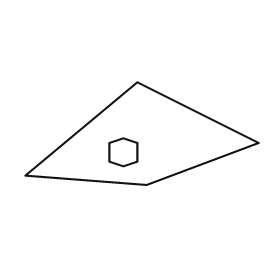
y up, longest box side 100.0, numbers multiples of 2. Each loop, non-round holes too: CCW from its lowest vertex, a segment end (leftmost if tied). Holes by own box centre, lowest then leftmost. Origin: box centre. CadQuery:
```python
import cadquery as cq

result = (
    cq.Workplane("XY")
    .moveTo(2.0, -22.0)
    .lineTo(50.0, -4.0)
    .lineTo(-2.0, 22.0)
    .lineTo(-50.0, -18.0)
    .close()
    .moveTo(-8.0, -14.0)
    .lineTo(-2.0, -12.0)
    .lineTo(-2.0, -4.0)
    .lineTo(-8.0, -2.0)
    .lineTo(-14.0, -4.0)
    .lineTo(-14.0, -12.0)
    .close()
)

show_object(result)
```